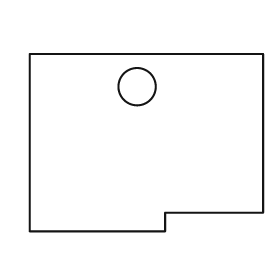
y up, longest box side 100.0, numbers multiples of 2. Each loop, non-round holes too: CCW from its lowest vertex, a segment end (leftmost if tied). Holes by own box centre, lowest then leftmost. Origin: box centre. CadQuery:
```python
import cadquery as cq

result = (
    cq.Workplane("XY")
    .moveTo(-50.0, -38.0)
    .lineTo(8.0, -38.0)
    .lineTo(8.0, -30.0)
    .lineTo(50.0, -30.0)
    .lineTo(50.0, 38.0)
    .lineTo(-50.0, 38.0)
    .close()
    .moveTo(-4.0, 24.0)
    .circle(8.0)
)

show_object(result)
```